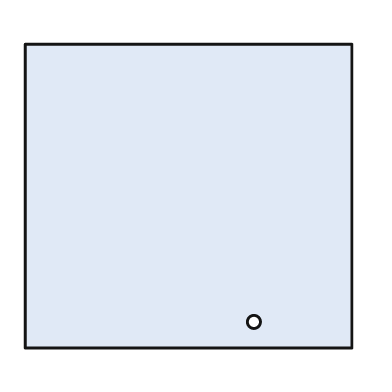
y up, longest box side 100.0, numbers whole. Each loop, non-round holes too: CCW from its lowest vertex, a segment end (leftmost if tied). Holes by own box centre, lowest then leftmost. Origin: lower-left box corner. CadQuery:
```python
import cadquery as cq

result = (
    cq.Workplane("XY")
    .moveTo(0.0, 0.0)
    .lineTo(100.0, 0.0)
    .lineTo(100.0, 93.0)
    .lineTo(0.0, 93.0)
    .close()
    .moveTo(70.0, 8.0)
    .circle(2.0)
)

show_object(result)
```